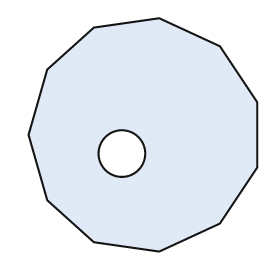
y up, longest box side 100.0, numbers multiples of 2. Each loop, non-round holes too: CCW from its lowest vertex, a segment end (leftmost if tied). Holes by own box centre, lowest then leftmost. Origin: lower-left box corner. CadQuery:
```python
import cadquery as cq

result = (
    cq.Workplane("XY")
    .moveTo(56.0, 0.0)
    .lineTo(82.0, 12.0)
    .lineTo(98.0, 36.0)
    .lineTo(98.0, 64.0)
    .lineTo(82.0, 88.0)
    .lineTo(56.0, 100.0)
    .lineTo(28.0, 96.0)
    .lineTo(8.0, 78.0)
    .lineTo(0.0, 50.0)
    .lineTo(8.0, 22.0)
    .lineTo(28.0, 4.0)
    .close()
    .moveTo(40.0, 42.0)
    .circle(10.0)
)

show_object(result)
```